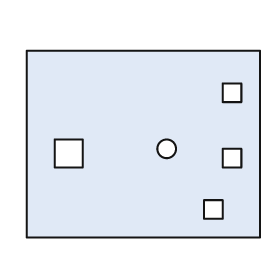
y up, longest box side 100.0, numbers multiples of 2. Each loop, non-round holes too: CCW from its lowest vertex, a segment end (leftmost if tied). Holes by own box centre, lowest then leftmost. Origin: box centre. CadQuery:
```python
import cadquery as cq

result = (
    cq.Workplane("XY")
    .moveTo(-50.0, -40.0)
    .lineTo(50.0, -40.0)
    .lineTo(50.0, 40.0)
    .lineTo(-50.0, 40.0)
    .close()
    .moveTo(26.0, -32.0)
    .lineTo(34.0, -32.0)
    .lineTo(34.0, -24.0)
    .lineTo(26.0, -24.0)
    .close()
    .moveTo(34.0, -10.0)
    .lineTo(42.0, -10.0)
    .lineTo(42.0, -2.0)
    .lineTo(34.0, -2.0)
    .close()
    .moveTo(-38.0, -10.0)
    .lineTo(-26.0, -10.0)
    .lineTo(-26.0, 2.0)
    .lineTo(-38.0, 2.0)
    .close()
    .moveTo(10.0, -2.0)
    .circle(4.0)
    .moveTo(34.0, 18.0)
    .lineTo(42.0, 18.0)
    .lineTo(42.0, 26.0)
    .lineTo(34.0, 26.0)
    .close()
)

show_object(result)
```